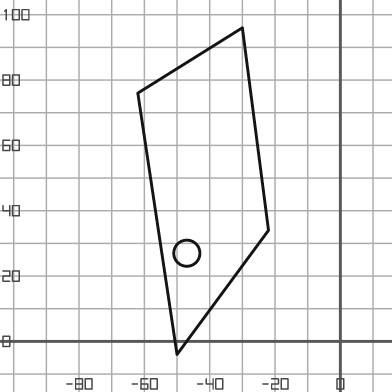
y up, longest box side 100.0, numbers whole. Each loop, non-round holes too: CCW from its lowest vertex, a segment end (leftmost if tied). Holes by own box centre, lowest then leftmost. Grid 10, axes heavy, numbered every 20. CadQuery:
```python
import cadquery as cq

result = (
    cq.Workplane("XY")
    .moveTo(-50.0, -4.0)
    .lineTo(-22.0, 34.0)
    .lineTo(-30.0, 96.0)
    .lineTo(-62.0, 76.0)
    .close()
    .moveTo(-47.0, 27.0)
    .circle(4.0)
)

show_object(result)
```